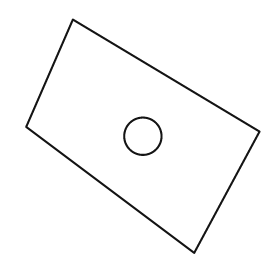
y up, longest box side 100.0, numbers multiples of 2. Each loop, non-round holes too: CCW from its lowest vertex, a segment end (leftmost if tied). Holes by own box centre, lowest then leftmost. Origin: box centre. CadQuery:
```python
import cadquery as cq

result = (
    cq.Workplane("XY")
    .moveTo(22.0, -50.0)
    .lineTo(50.0, 2.0)
    .lineTo(-30.0, 50.0)
    .lineTo(-50.0, 4.0)
    .close()
    .moveTo(0.0, 0.0)
    .circle(8.0)
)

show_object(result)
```